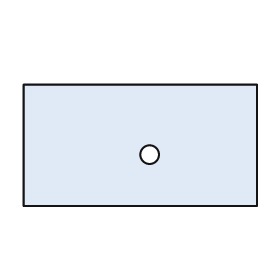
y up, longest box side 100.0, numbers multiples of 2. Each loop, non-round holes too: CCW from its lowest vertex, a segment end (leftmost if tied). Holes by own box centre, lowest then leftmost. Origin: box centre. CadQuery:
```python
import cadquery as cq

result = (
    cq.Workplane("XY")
    .moveTo(-50.0, -26.0)
    .lineTo(50.0, -26.0)
    .lineTo(50.0, 26.0)
    .lineTo(-50.0, 26.0)
    .close()
    .moveTo(4.0, -4.0)
    .circle(4.0)
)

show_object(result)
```